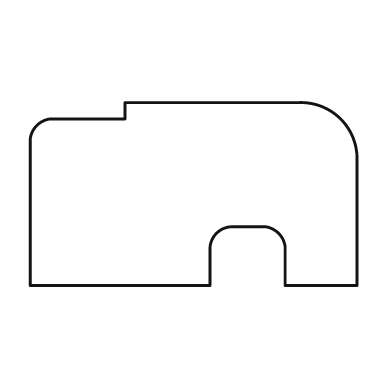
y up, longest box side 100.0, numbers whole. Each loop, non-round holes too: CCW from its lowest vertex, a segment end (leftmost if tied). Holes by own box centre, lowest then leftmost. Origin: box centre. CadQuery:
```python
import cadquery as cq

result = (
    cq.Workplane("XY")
    .moveTo(-50.0, -28.0)
    .lineTo(5.0, -28.0)
    .lineTo(5.0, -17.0)
    .threePointArc((7.0, -12.0), (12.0, -10.0))
    .lineTo(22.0, -10.0)
    .threePointArc((26.0, -12.0), (28.0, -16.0))
    .lineTo(28.0, -28.0)
    .lineTo(50.0, -28.0)
    .lineTo(50.0, 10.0)
    .threePointArc((45.0, 23.0), (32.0, 28.0))
    .lineTo(-21.0, 28.0)
    .lineTo(-21.0, 23.0)
    .lineTo(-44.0, 23.0)
    .threePointArc((-48.0, 21.0), (-50.0, 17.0))
    .close()
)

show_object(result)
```